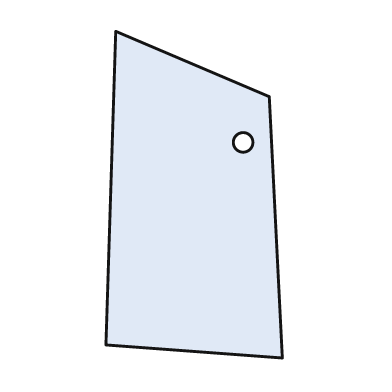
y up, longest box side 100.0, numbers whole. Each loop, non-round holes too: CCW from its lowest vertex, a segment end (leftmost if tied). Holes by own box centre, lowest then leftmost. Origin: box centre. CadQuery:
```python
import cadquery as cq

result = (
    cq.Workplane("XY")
    .moveTo(27.0, -50.0)
    .lineTo(23.0, 30.0)
    .lineTo(-24.0, 50.0)
    .lineTo(-27.0, -46.0)
    .close()
    .moveTo(15.0, 16.0)
    .circle(3.0)
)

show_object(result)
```